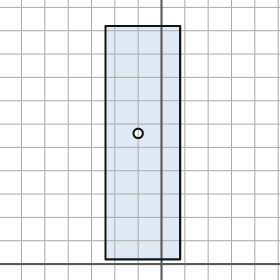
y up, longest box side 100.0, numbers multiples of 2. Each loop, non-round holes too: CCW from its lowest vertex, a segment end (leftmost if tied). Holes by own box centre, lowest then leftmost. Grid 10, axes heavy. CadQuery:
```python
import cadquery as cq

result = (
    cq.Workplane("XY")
    .moveTo(-24.0, 2.0)
    .lineTo(8.0, 2.0)
    .lineTo(8.0, 102.0)
    .lineTo(-24.0, 102.0)
    .close()
    .moveTo(-10.0, 56.0)
    .circle(2.0)
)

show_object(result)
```